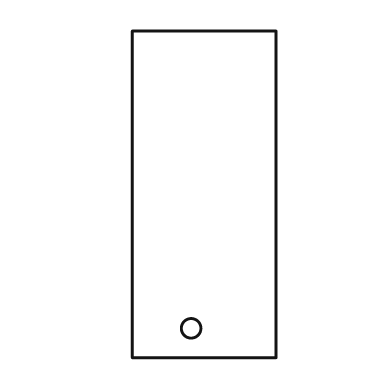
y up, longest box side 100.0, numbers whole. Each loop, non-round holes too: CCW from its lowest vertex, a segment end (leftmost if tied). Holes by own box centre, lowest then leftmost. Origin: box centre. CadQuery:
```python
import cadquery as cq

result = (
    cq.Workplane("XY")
    .moveTo(-22.0, -50.0)
    .lineTo(22.0, -50.0)
    .lineTo(22.0, 50.0)
    .lineTo(-22.0, 50.0)
    .close()
    .moveTo(-4.0, -41.0)
    .circle(3.0)
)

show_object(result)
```